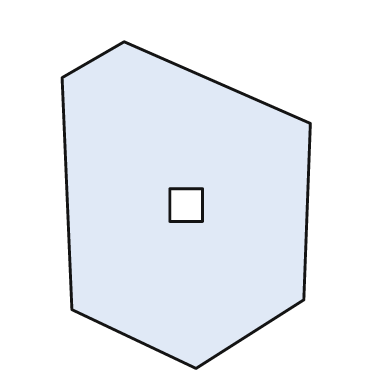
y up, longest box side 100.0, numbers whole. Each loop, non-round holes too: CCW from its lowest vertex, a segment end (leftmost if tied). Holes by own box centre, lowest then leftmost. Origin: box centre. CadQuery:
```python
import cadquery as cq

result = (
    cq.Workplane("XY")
    .moveTo(3.0, -50.0)
    .lineTo(36.0, -29.0)
    .lineTo(38.0, 25.0)
    .lineTo(-19.0, 50.0)
    .lineTo(-38.0, 39.0)
    .lineTo(-35.0, -32.0)
    .close()
    .moveTo(-5.0, -5.0)
    .lineTo(5.0, -5.0)
    .lineTo(5.0, 5.0)
    .lineTo(-5.0, 5.0)
    .close()
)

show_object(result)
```